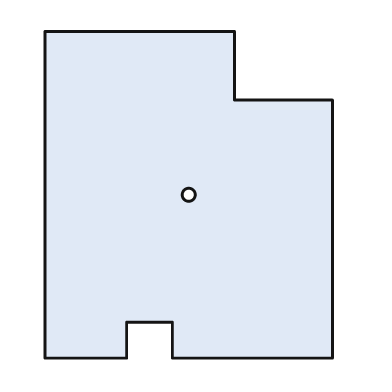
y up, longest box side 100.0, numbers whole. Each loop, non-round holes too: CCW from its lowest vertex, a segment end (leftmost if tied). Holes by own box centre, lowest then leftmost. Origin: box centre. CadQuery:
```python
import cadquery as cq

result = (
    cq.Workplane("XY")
    .moveTo(-44.0, -50.0)
    .lineTo(-19.0, -50.0)
    .lineTo(-19.0, -39.0)
    .lineTo(-5.0, -39.0)
    .lineTo(-5.0, -50.0)
    .lineTo(44.0, -50.0)
    .lineTo(44.0, 29.0)
    .lineTo(14.0, 29.0)
    .lineTo(14.0, 50.0)
    .lineTo(-44.0, 50.0)
    .close()
    .moveTo(0.0, 0.0)
    .circle(2.0)
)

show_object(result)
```